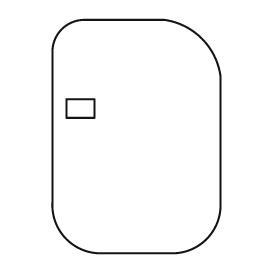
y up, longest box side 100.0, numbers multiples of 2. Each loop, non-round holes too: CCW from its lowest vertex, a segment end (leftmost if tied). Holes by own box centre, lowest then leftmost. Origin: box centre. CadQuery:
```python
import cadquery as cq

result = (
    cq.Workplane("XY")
    .moveTo(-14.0, -50.0)
    .lineTo(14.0, -50.0)
    .threePointArc((30.0, -44.0), (36.0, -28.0))
    .lineTo(36.0, 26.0)
    .threePointArc((28.0, 42.0), (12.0, 50.0))
    .lineTo(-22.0, 50.0)
    .threePointArc((-32.0, 46.0), (-36.0, 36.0))
    .lineTo(-36.0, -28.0)
    .threePointArc((-30.0, -44.0), (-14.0, -50.0))
    .close()
    .moveTo(-30.0, 8.0)
    .lineTo(-18.0, 8.0)
    .lineTo(-18.0, 16.0)
    .lineTo(-30.0, 16.0)
    .close()
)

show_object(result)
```